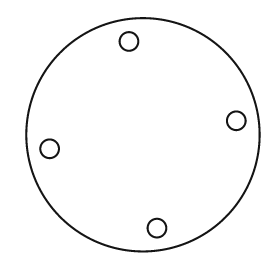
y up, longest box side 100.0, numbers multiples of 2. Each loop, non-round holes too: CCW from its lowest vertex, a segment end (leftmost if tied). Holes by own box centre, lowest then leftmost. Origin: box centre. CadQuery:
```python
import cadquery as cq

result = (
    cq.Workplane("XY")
    .moveTo(0.0, 0.0)
    .circle(50.0)
    .moveTo(6.0, -40.0)
    .circle(4.0)
    .moveTo(-40.0, -6.0)
    .circle(4.0)
    .moveTo(40.0, 6.0)
    .circle(4.0)
    .moveTo(-6.0, 40.0)
    .circle(4.0)
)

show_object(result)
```